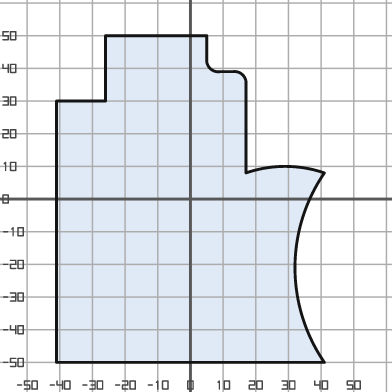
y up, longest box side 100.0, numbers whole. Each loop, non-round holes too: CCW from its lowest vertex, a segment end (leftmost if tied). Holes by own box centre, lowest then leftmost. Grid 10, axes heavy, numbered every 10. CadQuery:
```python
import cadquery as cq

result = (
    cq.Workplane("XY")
    .moveTo(-41.0, -50.0)
    .lineTo(41.0, -50.0)
    .threePointArc((32.0, -21.0), (41.0, 8.0))
    .threePointArc((29.0, 10.0), (17.0, 8.0))
    .lineTo(17.0, 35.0)
    .threePointArc((16.0, 38.0), (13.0, 39.0))
    .lineTo(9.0, 39.0)
    .threePointArc((6.0, 40.0), (5.0, 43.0))
    .lineTo(5.0, 50.0)
    .lineTo(-26.0, 50.0)
    .lineTo(-26.0, 30.0)
    .lineTo(-41.0, 30.0)
    .close()
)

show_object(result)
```